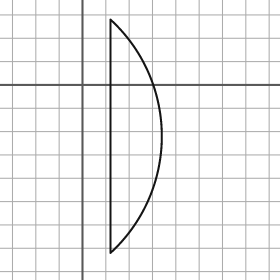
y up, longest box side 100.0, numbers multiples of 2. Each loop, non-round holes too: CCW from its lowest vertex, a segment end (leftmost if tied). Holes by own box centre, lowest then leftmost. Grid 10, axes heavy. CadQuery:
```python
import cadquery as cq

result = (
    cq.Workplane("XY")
    .moveTo(12.0, -72.0)
    .threePointArc((34.0, -22.0), (12.0, 28.0))
    .close()
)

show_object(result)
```